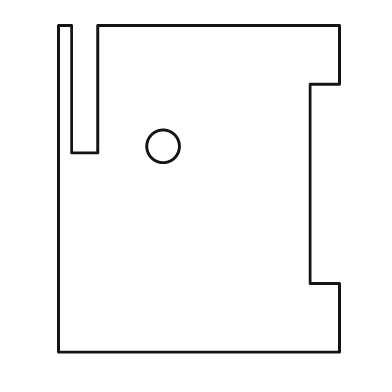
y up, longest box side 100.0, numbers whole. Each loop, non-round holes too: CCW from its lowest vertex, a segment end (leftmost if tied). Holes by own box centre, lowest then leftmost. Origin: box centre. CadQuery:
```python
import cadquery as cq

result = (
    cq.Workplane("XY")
    .moveTo(-43.0, -50.0)
    .lineTo(43.0, -50.0)
    .lineTo(43.0, -29.0)
    .lineTo(34.0, -29.0)
    .lineTo(34.0, 32.0)
    .lineTo(43.0, 32.0)
    .lineTo(43.0, 50.0)
    .lineTo(-31.0, 50.0)
    .lineTo(-31.0, 11.0)
    .lineTo(-39.0, 11.0)
    .lineTo(-39.0, 50.0)
    .lineTo(-43.0, 50.0)
    .close()
    .moveTo(-11.0, 13.0)
    .circle(5.0)
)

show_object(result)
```